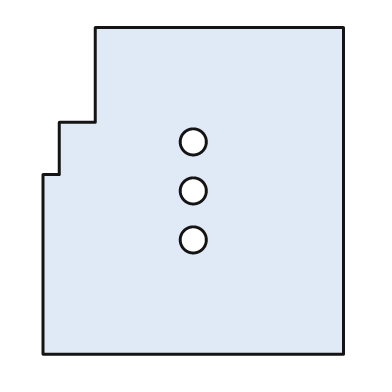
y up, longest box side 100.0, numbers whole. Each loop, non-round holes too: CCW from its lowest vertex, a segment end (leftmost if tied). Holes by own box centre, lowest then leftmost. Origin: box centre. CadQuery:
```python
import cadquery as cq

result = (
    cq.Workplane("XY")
    .moveTo(-46.0, -50.0)
    .lineTo(46.0, -50.0)
    .lineTo(46.0, 50.0)
    .lineTo(-30.0, 50.0)
    .lineTo(-30.0, 21.0)
    .lineTo(-41.0, 21.0)
    .lineTo(-41.0, 5.0)
    .lineTo(-46.0, 5.0)
    .close()
    .moveTo(0.0, -15.0)
    .circle(4.0)
    .moveTo(0.0, 0.0)
    .circle(4.0)
    .moveTo(0.0, 15.0)
    .circle(4.0)
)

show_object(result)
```